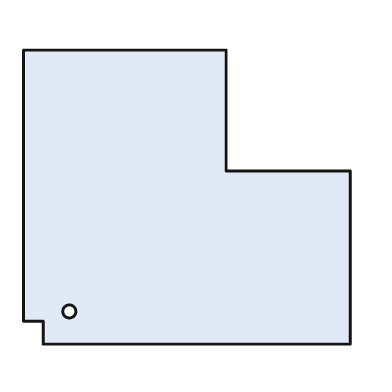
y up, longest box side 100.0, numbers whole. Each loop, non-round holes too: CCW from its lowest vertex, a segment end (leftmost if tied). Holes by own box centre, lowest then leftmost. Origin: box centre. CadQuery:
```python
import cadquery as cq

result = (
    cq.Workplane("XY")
    .moveTo(-44.0, -45.0)
    .lineTo(50.0, -45.0)
    .lineTo(50.0, 8.0)
    .lineTo(12.0, 8.0)
    .lineTo(12.0, 45.0)
    .lineTo(-50.0, 45.0)
    .lineTo(-50.0, -38.0)
    .lineTo(-44.0, -38.0)
    .close()
    .moveTo(-36.0, -35.0)
    .circle(2.0)
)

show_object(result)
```